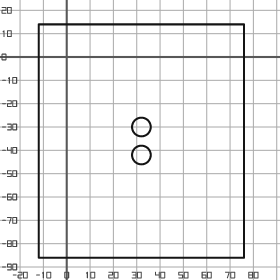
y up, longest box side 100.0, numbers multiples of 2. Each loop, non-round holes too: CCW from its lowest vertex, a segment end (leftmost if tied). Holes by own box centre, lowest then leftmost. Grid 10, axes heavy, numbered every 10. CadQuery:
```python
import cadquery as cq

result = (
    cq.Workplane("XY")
    .moveTo(-12.0, -86.0)
    .lineTo(76.0, -86.0)
    .lineTo(76.0, 14.0)
    .lineTo(-12.0, 14.0)
    .close()
    .moveTo(32.0, -42.0)
    .circle(4.0)
    .moveTo(32.0, -30.0)
    .circle(4.0)
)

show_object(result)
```